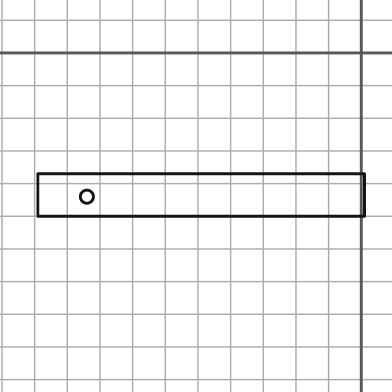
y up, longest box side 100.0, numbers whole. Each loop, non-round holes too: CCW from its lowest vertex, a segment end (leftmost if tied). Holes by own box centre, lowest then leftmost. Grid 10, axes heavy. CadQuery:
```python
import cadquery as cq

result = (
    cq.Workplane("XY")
    .moveTo(-99.0, -50.0)
    .lineTo(1.0, -50.0)
    .lineTo(1.0, -37.0)
    .lineTo(-99.0, -37.0)
    .close()
    .moveTo(-84.0, -44.0)
    .circle(2.0)
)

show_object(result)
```